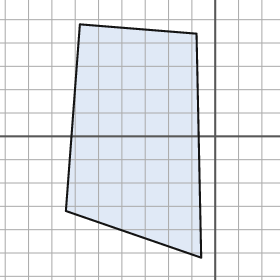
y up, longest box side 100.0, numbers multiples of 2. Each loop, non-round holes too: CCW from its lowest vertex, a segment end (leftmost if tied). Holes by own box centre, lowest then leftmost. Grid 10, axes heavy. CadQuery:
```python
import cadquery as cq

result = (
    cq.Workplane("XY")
    .moveTo(-6.0, -52.0)
    .lineTo(-8.0, 44.0)
    .lineTo(-58.0, 48.0)
    .lineTo(-64.0, -32.0)
    .close()
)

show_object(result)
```